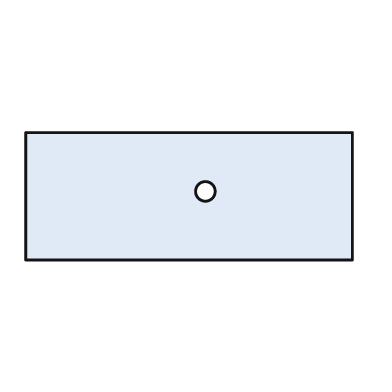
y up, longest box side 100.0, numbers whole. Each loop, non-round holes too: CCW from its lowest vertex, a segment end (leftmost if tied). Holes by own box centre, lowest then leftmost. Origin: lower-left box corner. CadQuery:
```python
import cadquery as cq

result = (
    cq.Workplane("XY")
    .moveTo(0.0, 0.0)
    .lineTo(100.0, 0.0)
    .lineTo(100.0, 39.0)
    .lineTo(0.0, 39.0)
    .close()
    .moveTo(55.0, 21.0)
    .circle(3.0)
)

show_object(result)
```